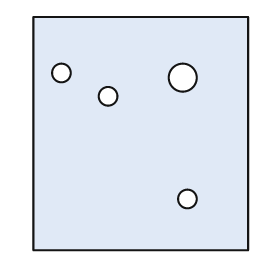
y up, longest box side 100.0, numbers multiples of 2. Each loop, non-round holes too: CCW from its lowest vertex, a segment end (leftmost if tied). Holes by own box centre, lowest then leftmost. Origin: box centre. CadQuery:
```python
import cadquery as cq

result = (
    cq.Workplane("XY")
    .moveTo(-46.0, -50.0)
    .lineTo(46.0, -50.0)
    .lineTo(46.0, 50.0)
    .lineTo(-46.0, 50.0)
    .close()
    .moveTo(20.0, -28.0)
    .circle(4.0)
    .moveTo(-14.0, 16.0)
    .circle(4.0)
    .moveTo(18.0, 24.0)
    .circle(6.0)
    .moveTo(-34.0, 26.0)
    .circle(4.0)
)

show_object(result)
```